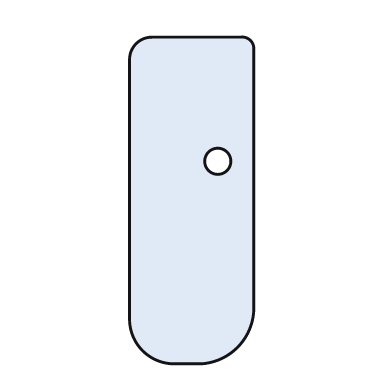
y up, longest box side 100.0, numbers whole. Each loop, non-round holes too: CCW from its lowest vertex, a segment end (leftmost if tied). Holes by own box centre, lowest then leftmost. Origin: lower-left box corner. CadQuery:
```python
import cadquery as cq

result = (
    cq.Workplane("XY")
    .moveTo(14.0, 0.0)
    .lineTo(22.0, 0.0)
    .threePointArc((33.0, 5.0), (38.0, 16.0))
    .lineTo(38.0, 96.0)
    .threePointArc((37.0, 99.0), (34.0, 100.0))
    .lineTo(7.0, 100.0)
    .threePointArc((2.0, 98.0), (0.0, 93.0))
    .lineTo(0.0, 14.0)
    .threePointArc((4.0, 4.0), (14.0, 0.0))
    .close()
    .moveTo(27.0, 62.0)
    .circle(4.0)
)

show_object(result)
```